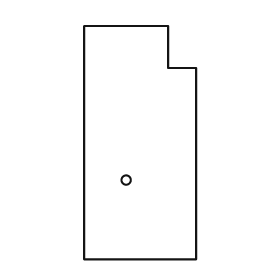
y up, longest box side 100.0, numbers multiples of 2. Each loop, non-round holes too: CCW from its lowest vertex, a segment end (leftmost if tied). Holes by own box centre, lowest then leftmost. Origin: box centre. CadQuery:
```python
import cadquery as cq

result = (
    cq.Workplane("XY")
    .moveTo(-24.0, -50.0)
    .lineTo(24.0, -50.0)
    .lineTo(24.0, 32.0)
    .lineTo(12.0, 32.0)
    .lineTo(12.0, 50.0)
    .lineTo(-24.0, 50.0)
    .close()
    .moveTo(-6.0, -16.0)
    .circle(2.0)
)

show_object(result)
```